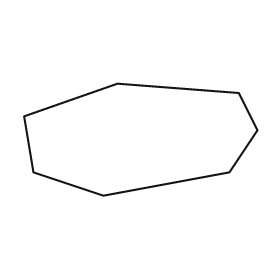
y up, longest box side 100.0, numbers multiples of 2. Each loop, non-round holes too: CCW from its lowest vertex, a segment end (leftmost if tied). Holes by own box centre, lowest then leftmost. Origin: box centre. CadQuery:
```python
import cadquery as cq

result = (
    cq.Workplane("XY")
    .moveTo(-16.0, -24.0)
    .lineTo(38.0, -14.0)
    .lineTo(50.0, 4.0)
    .lineTo(42.0, 20.0)
    .lineTo(-10.0, 24.0)
    .lineTo(-50.0, 10.0)
    .lineTo(-46.0, -14.0)
    .close()
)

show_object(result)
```